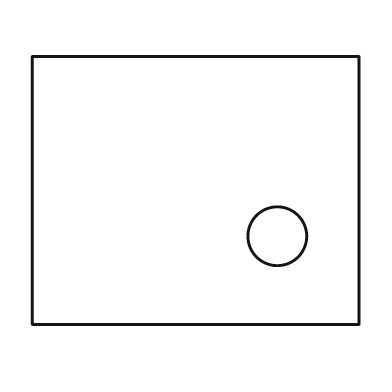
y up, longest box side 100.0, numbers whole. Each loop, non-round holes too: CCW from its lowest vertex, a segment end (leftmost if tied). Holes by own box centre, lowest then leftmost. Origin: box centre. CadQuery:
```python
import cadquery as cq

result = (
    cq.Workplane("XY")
    .moveTo(-50.0, -41.0)
    .lineTo(50.0, -41.0)
    .lineTo(50.0, 41.0)
    .lineTo(-50.0, 41.0)
    .close()
    .moveTo(25.0, -14.0)
    .circle(9.0)
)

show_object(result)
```